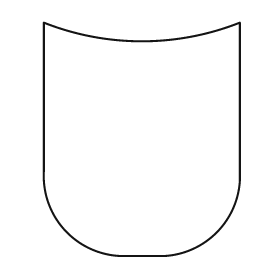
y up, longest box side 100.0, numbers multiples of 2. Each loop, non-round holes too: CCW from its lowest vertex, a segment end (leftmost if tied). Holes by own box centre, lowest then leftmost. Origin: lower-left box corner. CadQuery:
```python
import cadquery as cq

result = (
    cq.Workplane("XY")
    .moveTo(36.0, 0.0)
    .lineTo(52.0, 0.0)
    .threePointArc((74.0, 10.0), (84.0, 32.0))
    .lineTo(84.0, 100.0)
    .threePointArc((42.0, 92.0), (0.0, 100.0))
    .lineTo(0.0, 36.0)
    .threePointArc((10.0, 10.0), (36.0, 0.0))
    .close()
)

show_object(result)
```